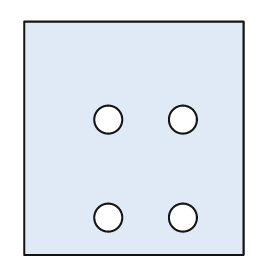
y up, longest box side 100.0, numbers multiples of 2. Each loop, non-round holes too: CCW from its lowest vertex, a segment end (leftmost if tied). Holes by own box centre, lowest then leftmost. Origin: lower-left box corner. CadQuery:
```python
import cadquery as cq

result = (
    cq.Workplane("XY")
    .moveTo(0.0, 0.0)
    .lineTo(94.0, 0.0)
    .lineTo(94.0, 100.0)
    .lineTo(0.0, 100.0)
    .close()
    .moveTo(36.0, 16.0)
    .circle(6.0)
    .moveTo(68.0, 16.0)
    .circle(6.0)
    .moveTo(36.0, 58.0)
    .circle(6.0)
    .moveTo(68.0, 58.0)
    .circle(6.0)
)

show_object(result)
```